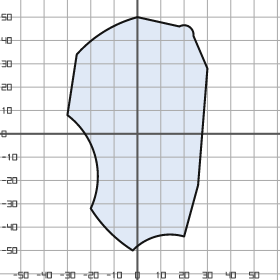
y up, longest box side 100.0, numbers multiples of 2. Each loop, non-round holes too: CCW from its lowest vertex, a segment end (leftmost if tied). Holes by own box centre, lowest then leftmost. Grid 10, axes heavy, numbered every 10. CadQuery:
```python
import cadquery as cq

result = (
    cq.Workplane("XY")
    .moveTo(-2.0, -50.0)
    .threePointArc((8.0, -44.0), (20.0, -44.0))
    .lineTo(26.0, -22.0)
    .lineTo(30.0, 28.0)
    .lineTo(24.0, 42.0)
    .threePointArc((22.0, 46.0), (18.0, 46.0))
    .lineTo(0.0, 50.0)
    .threePointArc((-14.0, 44.0), (-26.0, 34.0))
    .lineTo(-30.0, 8.0)
    .threePointArc((-18.0, -10.0), (-20.0, -32.0))
    .threePointArc((-12.0, -42.0), (-2.0, -50.0))
    .close()
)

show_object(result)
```